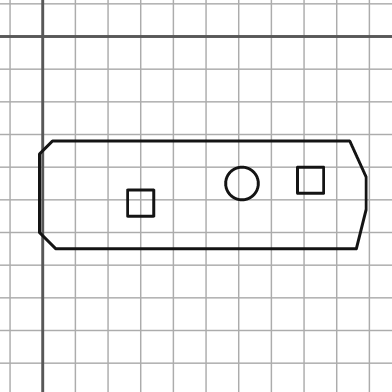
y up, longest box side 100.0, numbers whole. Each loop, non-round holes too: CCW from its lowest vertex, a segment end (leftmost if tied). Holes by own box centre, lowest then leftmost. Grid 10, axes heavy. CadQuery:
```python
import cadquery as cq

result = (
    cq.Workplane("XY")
    .moveTo(4.0, -65.0)
    .lineTo(96.0, -65.0)
    .lineTo(99.0, -53.0)
    .lineTo(99.0, -43.0)
    .lineTo(94.0, -32.0)
    .lineTo(3.0, -32.0)
    .lineTo(-1.0, -36.0)
    .lineTo(-1.0, -60.0)
    .close()
    .moveTo(26.0, -55.0)
    .lineTo(34.0, -55.0)
    .lineTo(34.0, -47.0)
    .lineTo(26.0, -47.0)
    .close()
    .moveTo(61.0, -45.0)
    .circle(5.0)
    .moveTo(78.0, -48.0)
    .lineTo(86.0, -48.0)
    .lineTo(86.0, -40.0)
    .lineTo(78.0, -40.0)
    .close()
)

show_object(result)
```